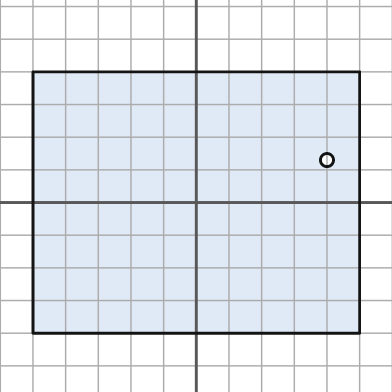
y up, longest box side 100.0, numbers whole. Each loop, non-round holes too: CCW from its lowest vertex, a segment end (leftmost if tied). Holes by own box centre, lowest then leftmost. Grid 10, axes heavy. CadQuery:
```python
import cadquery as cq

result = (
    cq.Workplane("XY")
    .moveTo(-50.0, -40.0)
    .lineTo(50.0, -40.0)
    .lineTo(50.0, 40.0)
    .lineTo(-50.0, 40.0)
    .close()
    .moveTo(40.0, 13.0)
    .circle(2.0)
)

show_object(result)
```